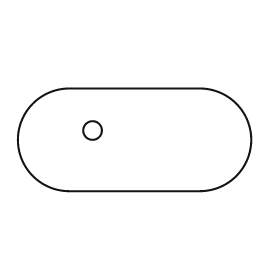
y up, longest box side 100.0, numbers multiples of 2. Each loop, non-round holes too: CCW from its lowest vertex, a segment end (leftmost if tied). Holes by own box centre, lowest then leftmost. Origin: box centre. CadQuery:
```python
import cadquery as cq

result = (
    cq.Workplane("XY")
    .moveTo(-28.0, -22.0)
    .lineTo(28.0, -22.0)
    .threePointArc((50.0, 0.0), (28.0, 22.0))
    .lineTo(-28.0, 22.0)
    .threePointArc((-50.0, 0.0), (-28.0, -22.0))
    .close()
    .moveTo(-18.0, 4.0)
    .circle(4.0)
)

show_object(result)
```